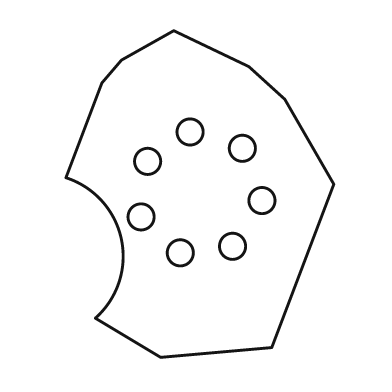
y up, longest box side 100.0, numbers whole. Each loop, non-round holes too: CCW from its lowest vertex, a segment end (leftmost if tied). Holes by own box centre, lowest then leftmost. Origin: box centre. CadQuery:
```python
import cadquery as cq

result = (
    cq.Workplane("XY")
    .moveTo(-12.0, -50.0)
    .lineTo(22.0, -47.0)
    .lineTo(41.0, 3.0)
    .lineTo(26.0, 29.0)
    .lineTo(15.0, 39.0)
    .lineTo(-8.0, 50.0)
    .lineTo(-24.0, 41.0)
    .lineTo(-30.0, 34.0)
    .lineTo(-41.0, 5.0)
    .threePointArc((-24.0, -14.0), (-32.0, -38.0))
    .close()
    .moveTo(-6.0, -18.0)
    .circle(4.0)
    .moveTo(10.0, -16.0)
    .circle(4.0)
    .moveTo(-18.0, -7.0)
    .circle(4.0)
    .moveTo(19.0, -2.0)
    .circle(4.0)
    .moveTo(-16.0, 10.0)
    .circle(4.0)
    .moveTo(13.0, 14.0)
    .circle(4.0)
    .moveTo(-3.0, 19.0)
    .circle(4.0)
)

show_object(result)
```